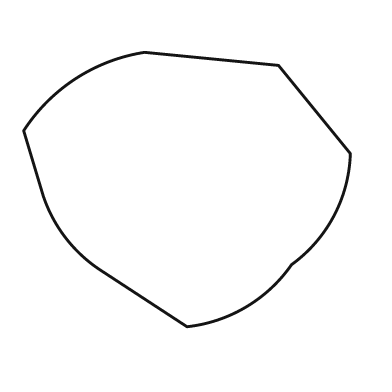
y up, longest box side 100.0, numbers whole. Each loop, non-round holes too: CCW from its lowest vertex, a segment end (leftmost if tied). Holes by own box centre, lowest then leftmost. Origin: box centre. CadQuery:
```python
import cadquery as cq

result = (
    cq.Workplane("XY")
    .moveTo(0.0, -42.0)
    .threePointArc((18.0, -36.0), (32.0, -23.0))
    .threePointArc((45.0, -8.0), (50.0, 11.0))
    .lineTo(28.0, 38.0)
    .lineTo(-13.0, 42.0)
    .threePointArc((-34.0, 34.0), (-50.0, 18.0))
    .lineTo(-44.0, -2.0)
    .threePointArc((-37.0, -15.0), (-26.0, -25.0))
    .close()
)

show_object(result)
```